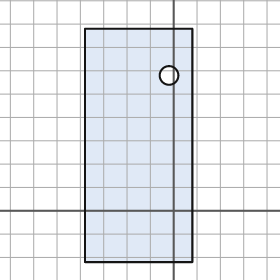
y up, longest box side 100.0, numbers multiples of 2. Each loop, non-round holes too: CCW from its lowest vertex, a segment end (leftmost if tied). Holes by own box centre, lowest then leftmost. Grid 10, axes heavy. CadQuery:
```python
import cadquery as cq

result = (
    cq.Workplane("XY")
    .moveTo(-38.0, -22.0)
    .lineTo(8.0, -22.0)
    .lineTo(8.0, 78.0)
    .lineTo(-38.0, 78.0)
    .close()
    .moveTo(-2.0, 58.0)
    .circle(4.0)
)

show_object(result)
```